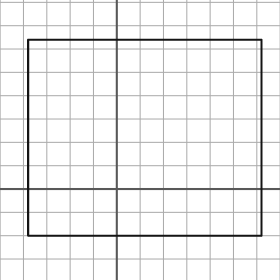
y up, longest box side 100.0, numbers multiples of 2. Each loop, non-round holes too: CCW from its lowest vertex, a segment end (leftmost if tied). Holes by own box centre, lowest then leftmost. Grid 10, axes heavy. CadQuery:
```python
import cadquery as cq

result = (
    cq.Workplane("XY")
    .moveTo(-38.0, -20.0)
    .lineTo(62.0, -20.0)
    .lineTo(62.0, 64.0)
    .lineTo(-38.0, 64.0)
    .close()
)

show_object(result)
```